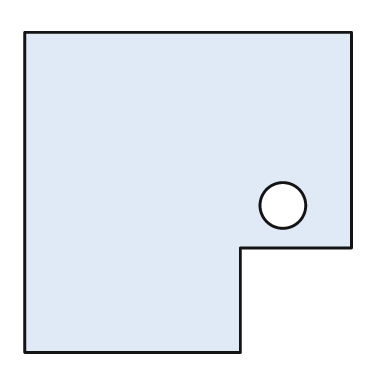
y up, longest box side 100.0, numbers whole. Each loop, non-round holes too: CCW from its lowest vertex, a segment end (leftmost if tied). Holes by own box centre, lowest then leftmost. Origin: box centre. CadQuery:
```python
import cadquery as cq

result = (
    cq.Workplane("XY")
    .moveTo(-50.0, -49.0)
    .lineTo(16.0, -49.0)
    .lineTo(16.0, -17.0)
    .lineTo(50.0, -17.0)
    .lineTo(50.0, 49.0)
    .lineTo(-50.0, 49.0)
    .close()
    .moveTo(29.0, -4.0)
    .circle(7.0)
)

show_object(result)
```